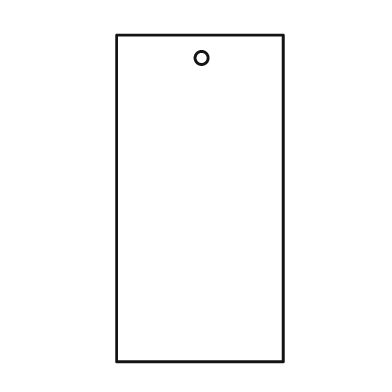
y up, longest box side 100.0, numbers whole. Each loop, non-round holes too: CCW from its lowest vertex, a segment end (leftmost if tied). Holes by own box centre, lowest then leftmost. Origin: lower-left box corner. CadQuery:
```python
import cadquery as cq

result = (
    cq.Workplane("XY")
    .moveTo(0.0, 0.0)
    .lineTo(51.0, 0.0)
    .lineTo(51.0, 100.0)
    .lineTo(0.0, 100.0)
    .close()
    .moveTo(26.0, 93.0)
    .circle(2.0)
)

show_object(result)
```